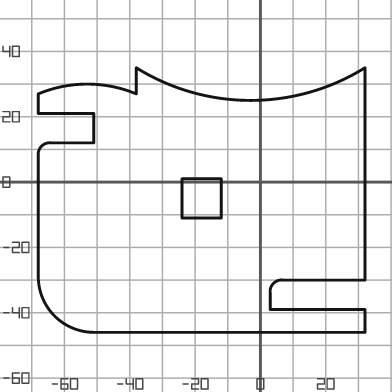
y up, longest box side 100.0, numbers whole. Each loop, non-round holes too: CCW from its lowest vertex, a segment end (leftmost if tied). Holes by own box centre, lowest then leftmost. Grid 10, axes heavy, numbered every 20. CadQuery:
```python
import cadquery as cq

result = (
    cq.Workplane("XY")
    .moveTo(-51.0, -46.0)
    .lineTo(32.0, -46.0)
    .lineTo(32.0, -39.0)
    .lineTo(3.0, -39.0)
    .lineTo(3.0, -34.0)
    .threePointArc((4.0, -31.0), (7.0, -30.0))
    .lineTo(32.0, -30.0)
    .lineTo(32.0, 35.0)
    .threePointArc((-3.0, 25.0), (-38.0, 35.0))
    .lineTo(-38.0, 27.0)
    .threePointArc((-53.0, 30.0), (-68.0, 27.0))
    .lineTo(-68.0, 21.0)
    .lineTo(-51.0, 21.0)
    .lineTo(-51.0, 12.0)
    .lineTo(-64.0, 12.0)
    .threePointArc((-67.0, 11.0), (-68.0, 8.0))
    .lineTo(-68.0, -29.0)
    .threePointArc((-63.0, -41.0), (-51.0, -46.0))
    .close()
    .moveTo(-24.0, -11.0)
    .lineTo(-12.0, -11.0)
    .lineTo(-12.0, 1.0)
    .lineTo(-24.0, 1.0)
    .close()
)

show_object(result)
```